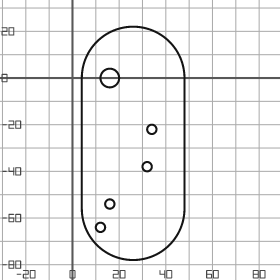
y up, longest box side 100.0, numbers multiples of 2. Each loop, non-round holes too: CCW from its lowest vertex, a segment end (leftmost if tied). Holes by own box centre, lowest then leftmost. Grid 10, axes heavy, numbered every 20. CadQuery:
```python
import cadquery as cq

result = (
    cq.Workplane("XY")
    .moveTo(4.0, -56.0)
    .threePointArc((26.0, -78.0), (48.0, -56.0))
    .lineTo(48.0, 0.0)
    .threePointArc((26.0, 22.0), (4.0, 0.0))
    .close()
    .moveTo(12.0, -64.0)
    .circle(2.0)
    .moveTo(16.0, -54.0)
    .circle(2.0)
    .moveTo(32.0, -38.0)
    .circle(2.0)
    .moveTo(34.0, -22.0)
    .circle(2.0)
    .moveTo(16.0, 0.0)
    .circle(4.0)
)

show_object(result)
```